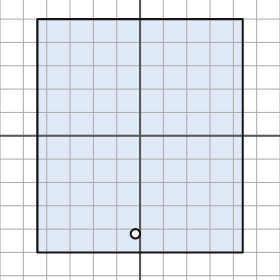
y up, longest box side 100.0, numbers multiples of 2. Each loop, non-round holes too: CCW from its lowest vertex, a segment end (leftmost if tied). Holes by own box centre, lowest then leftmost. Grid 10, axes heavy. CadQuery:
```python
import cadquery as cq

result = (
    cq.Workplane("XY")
    .moveTo(-44.0, -50.0)
    .lineTo(44.0, -50.0)
    .lineTo(44.0, 50.0)
    .lineTo(-44.0, 50.0)
    .close()
    .moveTo(-2.0, -42.0)
    .circle(2.0)
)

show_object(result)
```